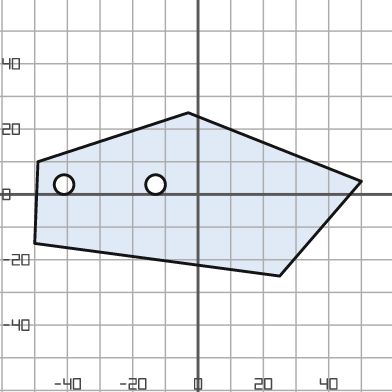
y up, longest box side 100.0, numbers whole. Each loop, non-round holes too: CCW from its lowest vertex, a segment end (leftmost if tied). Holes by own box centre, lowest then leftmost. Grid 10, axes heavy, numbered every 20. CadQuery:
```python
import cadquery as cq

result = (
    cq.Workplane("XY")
    .moveTo(25.0, -25.0)
    .lineTo(50.0, 4.0)
    .lineTo(-3.0, 25.0)
    .lineTo(-49.0, 10.0)
    .lineTo(-50.0, -15.0)
    .close()
    .moveTo(-41.0, 3.0)
    .circle(3.0)
    .moveTo(-13.0, 3.0)
    .circle(3.0)
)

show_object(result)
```